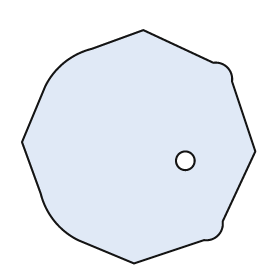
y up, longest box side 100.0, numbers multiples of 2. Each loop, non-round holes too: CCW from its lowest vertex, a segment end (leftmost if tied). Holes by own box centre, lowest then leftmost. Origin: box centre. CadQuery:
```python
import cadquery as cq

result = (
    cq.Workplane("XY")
    .moveTo(-2.0, -50.0)
    .lineTo(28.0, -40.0)
    .threePointArc((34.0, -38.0), (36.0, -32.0))
    .lineTo(50.0, -2.0)
    .lineTo(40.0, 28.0)
    .threePointArc((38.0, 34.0), (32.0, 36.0))
    .lineTo(2.0, 50.0)
    .lineTo(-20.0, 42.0)
    .threePointArc((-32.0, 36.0), (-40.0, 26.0))
    .lineTo(-50.0, 2.0)
    .lineTo(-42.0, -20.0)
    .threePointArc((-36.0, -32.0), (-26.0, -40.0))
    .close()
    .moveTo(20.0, -6.0)
    .circle(4.0)
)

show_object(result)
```